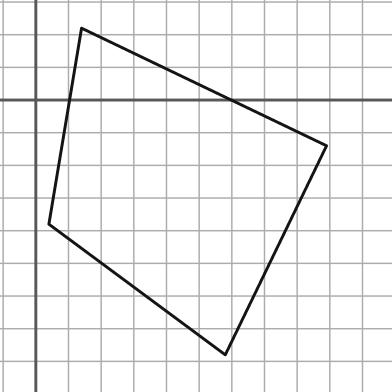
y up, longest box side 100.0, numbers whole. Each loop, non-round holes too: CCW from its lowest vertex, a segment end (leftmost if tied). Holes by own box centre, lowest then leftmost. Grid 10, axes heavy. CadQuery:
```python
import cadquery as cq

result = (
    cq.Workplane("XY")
    .moveTo(58.0, -78.0)
    .lineTo(89.0, -14.0)
    .lineTo(14.0, 22.0)
    .lineTo(4.0, -38.0)
    .close()
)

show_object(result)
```